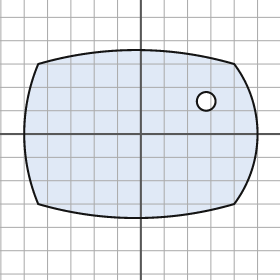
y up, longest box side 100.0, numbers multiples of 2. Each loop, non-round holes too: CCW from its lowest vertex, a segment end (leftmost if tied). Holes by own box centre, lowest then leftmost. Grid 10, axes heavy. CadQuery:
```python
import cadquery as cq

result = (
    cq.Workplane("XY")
    .moveTo(-44.0, -30.0)
    .threePointArc((-2.0, -36.0), (40.0, -30.0))
    .threePointArc((50.0, 0.0), (40.0, 30.0))
    .threePointArc((-2.0, 36.0), (-44.0, 30.0))
    .threePointArc((-50.0, 0.0), (-44.0, -30.0))
    .close()
    .moveTo(28.0, 14.0)
    .circle(4.0)
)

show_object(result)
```